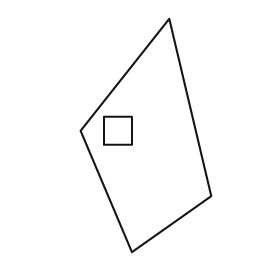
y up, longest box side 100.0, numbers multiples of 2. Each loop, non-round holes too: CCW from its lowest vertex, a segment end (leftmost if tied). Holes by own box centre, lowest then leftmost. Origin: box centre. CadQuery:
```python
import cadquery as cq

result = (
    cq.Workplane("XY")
    .moveTo(-6.0, -50.0)
    .lineTo(28.0, -26.0)
    .lineTo(10.0, 50.0)
    .lineTo(-28.0, 2.0)
    .close()
    .moveTo(-18.0, -4.0)
    .lineTo(-6.0, -4.0)
    .lineTo(-6.0, 8.0)
    .lineTo(-18.0, 8.0)
    .close()
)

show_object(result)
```